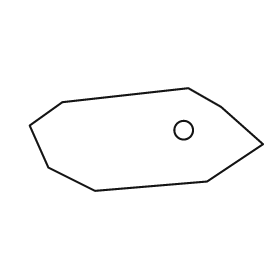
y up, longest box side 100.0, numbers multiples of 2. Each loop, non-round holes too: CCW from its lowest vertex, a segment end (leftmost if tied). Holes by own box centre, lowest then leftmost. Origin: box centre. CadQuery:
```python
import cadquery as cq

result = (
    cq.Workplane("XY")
    .moveTo(-22.0, -22.0)
    .lineTo(26.0, -18.0)
    .lineTo(50.0, -2.0)
    .lineTo(32.0, 14.0)
    .lineTo(18.0, 22.0)
    .lineTo(-36.0, 16.0)
    .lineTo(-50.0, 6.0)
    .lineTo(-42.0, -12.0)
    .close()
    .moveTo(16.0, 4.0)
    .circle(4.0)
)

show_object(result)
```